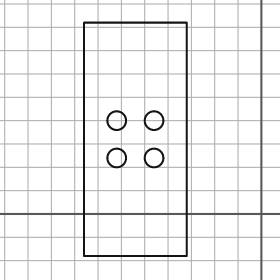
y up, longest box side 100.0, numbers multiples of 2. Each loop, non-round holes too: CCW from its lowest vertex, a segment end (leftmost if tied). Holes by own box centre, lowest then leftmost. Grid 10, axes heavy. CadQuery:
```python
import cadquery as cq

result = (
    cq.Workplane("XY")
    .moveTo(-76.0, -18.0)
    .lineTo(-32.0, -18.0)
    .lineTo(-32.0, 82.0)
    .lineTo(-76.0, 82.0)
    .close()
    .moveTo(-62.0, 24.0)
    .circle(4.0)
    .moveTo(-46.0, 24.0)
    .circle(4.0)
    .moveTo(-62.0, 40.0)
    .circle(4.0)
    .moveTo(-46.0, 40.0)
    .circle(4.0)
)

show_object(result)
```